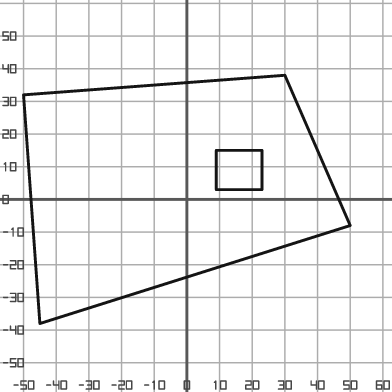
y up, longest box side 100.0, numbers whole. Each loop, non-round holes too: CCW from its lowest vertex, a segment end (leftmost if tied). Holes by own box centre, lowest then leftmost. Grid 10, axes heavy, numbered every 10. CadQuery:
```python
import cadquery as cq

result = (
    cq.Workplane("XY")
    .moveTo(-45.0, -38.0)
    .lineTo(50.0, -8.0)
    .lineTo(30.0, 38.0)
    .lineTo(-50.0, 32.0)
    .close()
    .moveTo(9.0, 3.0)
    .lineTo(23.0, 3.0)
    .lineTo(23.0, 15.0)
    .lineTo(9.0, 15.0)
    .close()
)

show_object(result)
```